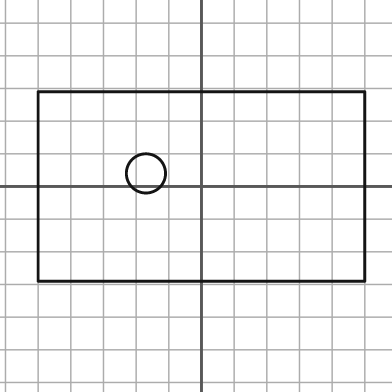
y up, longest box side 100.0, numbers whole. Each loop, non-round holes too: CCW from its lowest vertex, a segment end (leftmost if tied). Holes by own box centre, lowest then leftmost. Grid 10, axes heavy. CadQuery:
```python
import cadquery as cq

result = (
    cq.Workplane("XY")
    .moveTo(-50.0, -29.0)
    .lineTo(50.0, -29.0)
    .lineTo(50.0, 29.0)
    .lineTo(-50.0, 29.0)
    .close()
    .moveTo(-17.0, 4.0)
    .circle(6.0)
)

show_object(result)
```